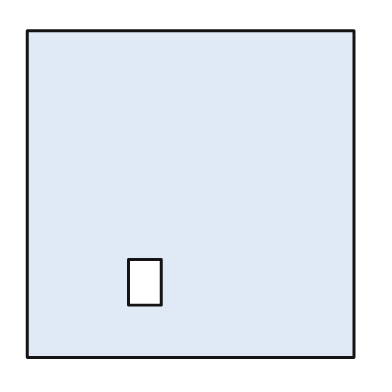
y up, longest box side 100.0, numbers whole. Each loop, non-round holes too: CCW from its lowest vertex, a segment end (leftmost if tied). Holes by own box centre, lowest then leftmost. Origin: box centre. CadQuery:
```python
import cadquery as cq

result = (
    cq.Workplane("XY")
    .moveTo(-50.0, -50.0)
    .lineTo(50.0, -50.0)
    .lineTo(50.0, 50.0)
    .lineTo(-50.0, 50.0)
    .close()
    .moveTo(-19.0, -34.0)
    .lineTo(-9.0, -34.0)
    .lineTo(-9.0, -20.0)
    .lineTo(-19.0, -20.0)
    .close()
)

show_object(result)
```